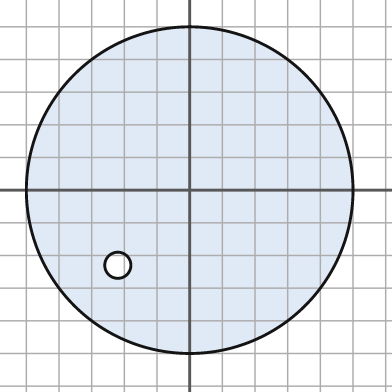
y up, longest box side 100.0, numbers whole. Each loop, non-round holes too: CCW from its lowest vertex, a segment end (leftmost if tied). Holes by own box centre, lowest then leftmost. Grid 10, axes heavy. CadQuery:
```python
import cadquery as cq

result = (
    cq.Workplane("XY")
    .moveTo(0.0, 0.0)
    .circle(50.0)
    .moveTo(-22.0, -23.0)
    .circle(4.0)
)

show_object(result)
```